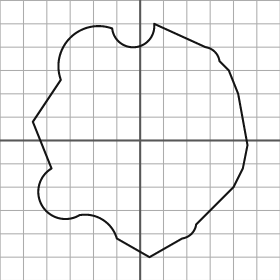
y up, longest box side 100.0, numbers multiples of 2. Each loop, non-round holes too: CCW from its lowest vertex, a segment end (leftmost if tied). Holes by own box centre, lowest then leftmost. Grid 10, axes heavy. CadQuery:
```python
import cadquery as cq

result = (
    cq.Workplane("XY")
    .moveTo(4.0, -50.0)
    .lineTo(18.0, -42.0)
    .threePointArc((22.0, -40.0), (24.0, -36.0))
    .lineTo(40.0, -20.0)
    .lineTo(44.0, -12.0)
    .lineTo(46.0, -2.0)
    .lineTo(42.0, 20.0)
    .lineTo(38.0, 30.0)
    .lineTo(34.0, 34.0)
    .threePointArc((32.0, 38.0), (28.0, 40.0))
    .lineTo(6.0, 50.0)
    .threePointArc((-2.0, 40.0), (-12.0, 48.0))
    .threePointArc((-30.0, 44.0), (-34.0, 26.0))
    .lineTo(-46.0, 8.0)
    .lineTo(-38.0, -12.0)
    .threePointArc((-42.0, -28.0), (-26.0, -32.0))
    .threePointArc((-16.0, -34.0), (-10.0, -42.0))
    .close()
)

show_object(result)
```